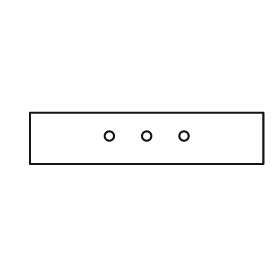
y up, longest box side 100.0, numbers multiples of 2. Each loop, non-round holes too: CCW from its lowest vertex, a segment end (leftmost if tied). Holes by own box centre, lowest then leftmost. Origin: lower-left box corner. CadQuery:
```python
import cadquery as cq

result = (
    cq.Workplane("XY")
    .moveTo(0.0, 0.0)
    .lineTo(100.0, 0.0)
    .lineTo(100.0, 22.0)
    .lineTo(0.0, 22.0)
    .close()
    .moveTo(34.0, 12.0)
    .circle(2.0)
    .moveTo(50.0, 12.0)
    .circle(2.0)
    .moveTo(66.0, 12.0)
    .circle(2.0)
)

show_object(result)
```